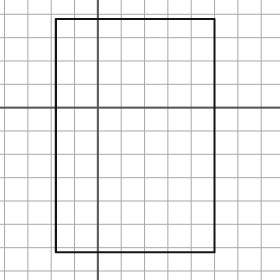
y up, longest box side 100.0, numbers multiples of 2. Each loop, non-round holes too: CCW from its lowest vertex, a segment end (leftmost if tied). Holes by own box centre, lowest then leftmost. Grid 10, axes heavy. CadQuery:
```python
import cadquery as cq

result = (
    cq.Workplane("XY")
    .moveTo(-18.0, -62.0)
    .lineTo(50.0, -62.0)
    .lineTo(50.0, 38.0)
    .lineTo(-18.0, 38.0)
    .close()
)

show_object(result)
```